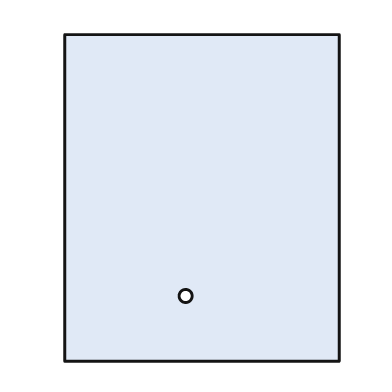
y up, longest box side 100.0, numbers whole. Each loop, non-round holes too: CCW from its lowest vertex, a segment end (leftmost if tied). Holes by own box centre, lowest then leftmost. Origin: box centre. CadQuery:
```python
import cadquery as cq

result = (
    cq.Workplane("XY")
    .moveTo(-42.0, -50.0)
    .lineTo(42.0, -50.0)
    .lineTo(42.0, 50.0)
    .lineTo(-42.0, 50.0)
    .close()
    .moveTo(-5.0, -30.0)
    .circle(2.0)
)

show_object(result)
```